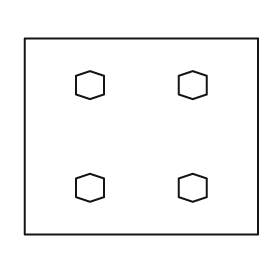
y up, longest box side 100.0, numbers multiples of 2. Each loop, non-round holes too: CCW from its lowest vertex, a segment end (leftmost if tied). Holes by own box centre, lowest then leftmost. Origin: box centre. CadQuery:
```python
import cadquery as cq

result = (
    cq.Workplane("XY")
    .moveTo(-50.0, -42.0)
    .lineTo(50.0, -42.0)
    .lineTo(50.0, 42.0)
    .lineTo(-50.0, 42.0)
    .close()
    .moveTo(-22.0, -28.0)
    .lineTo(-16.0, -26.0)
    .lineTo(-16.0, -18.0)
    .lineTo(-22.0, -16.0)
    .lineTo(-28.0, -18.0)
    .lineTo(-28.0, -26.0)
    .close()
    .moveTo(22.0, -28.0)
    .lineTo(28.0, -26.0)
    .lineTo(28.0, -18.0)
    .lineTo(22.0, -16.0)
    .lineTo(16.0, -18.0)
    .lineTo(16.0, -26.0)
    .close()
    .moveTo(-22.0, 16.0)
    .lineTo(-16.0, 18.0)
    .lineTo(-16.0, 26.0)
    .lineTo(-22.0, 28.0)
    .lineTo(-28.0, 26.0)
    .lineTo(-28.0, 18.0)
    .close()
    .moveTo(22.0, 16.0)
    .lineTo(28.0, 18.0)
    .lineTo(28.0, 26.0)
    .lineTo(22.0, 28.0)
    .lineTo(16.0, 26.0)
    .lineTo(16.0, 18.0)
    .close()
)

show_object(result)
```